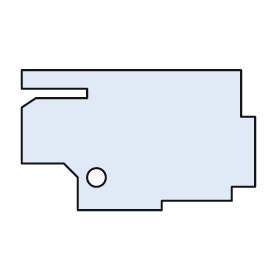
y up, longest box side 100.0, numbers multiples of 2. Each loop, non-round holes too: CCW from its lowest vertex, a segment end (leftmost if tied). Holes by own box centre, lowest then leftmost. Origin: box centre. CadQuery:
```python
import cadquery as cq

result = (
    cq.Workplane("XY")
    .moveTo(-26.0, -30.0)
    .lineTo(10.0, -30.0)
    .lineTo(10.0, -26.0)
    .lineTo(40.0, -26.0)
    .lineTo(40.0, -20.0)
    .lineTo(50.0, -20.0)
    .lineTo(50.0, 10.0)
    .lineTo(44.0, 10.0)
    .lineTo(44.0, 30.0)
    .lineTo(-50.0, 30.0)
    .lineTo(-50.0, 22.0)
    .lineTo(-22.0, 22.0)
    .lineTo(-22.0, 18.0)
    .lineTo(-44.0, 18.0)
    .lineTo(-50.0, 14.0)
    .lineTo(-50.0, -10.0)
    .lineTo(-32.0, -10.0)
    .lineTo(-26.0, -16.0)
    .close()
    .moveTo(-18.0, -16.0)
    .circle(4.0)
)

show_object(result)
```